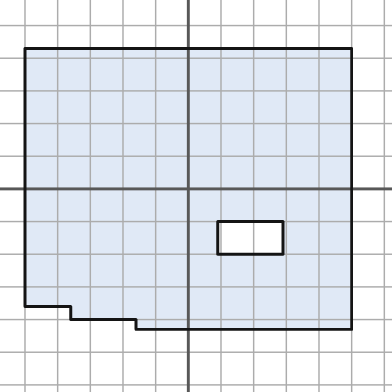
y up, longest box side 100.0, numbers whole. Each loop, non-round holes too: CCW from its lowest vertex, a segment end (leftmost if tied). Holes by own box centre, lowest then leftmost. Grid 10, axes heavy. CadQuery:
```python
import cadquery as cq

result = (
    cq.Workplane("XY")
    .moveTo(-16.0, -43.0)
    .lineTo(50.0, -43.0)
    .lineTo(50.0, 43.0)
    .lineTo(-50.0, 43.0)
    .lineTo(-50.0, -36.0)
    .lineTo(-36.0, -36.0)
    .lineTo(-36.0, -40.0)
    .lineTo(-16.0, -40.0)
    .close()
    .moveTo(9.0, -20.0)
    .lineTo(29.0, -20.0)
    .lineTo(29.0, -10.0)
    .lineTo(9.0, -10.0)
    .close()
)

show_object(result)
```